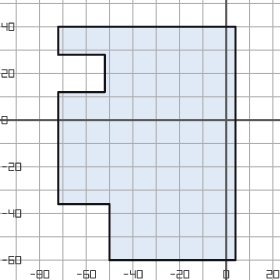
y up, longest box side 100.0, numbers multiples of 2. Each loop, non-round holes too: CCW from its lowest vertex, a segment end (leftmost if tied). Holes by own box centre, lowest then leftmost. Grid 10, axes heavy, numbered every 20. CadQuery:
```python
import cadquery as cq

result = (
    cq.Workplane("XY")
    .moveTo(-50.0, -60.0)
    .lineTo(4.0, -60.0)
    .lineTo(4.0, 40.0)
    .lineTo(-72.0, 40.0)
    .lineTo(-72.0, 28.0)
    .lineTo(-52.0, 28.0)
    .lineTo(-52.0, 12.0)
    .lineTo(-72.0, 12.0)
    .lineTo(-72.0, -36.0)
    .lineTo(-50.0, -36.0)
    .close()
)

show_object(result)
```